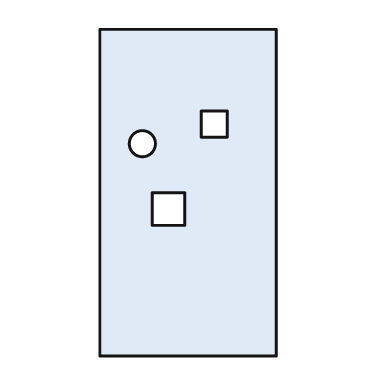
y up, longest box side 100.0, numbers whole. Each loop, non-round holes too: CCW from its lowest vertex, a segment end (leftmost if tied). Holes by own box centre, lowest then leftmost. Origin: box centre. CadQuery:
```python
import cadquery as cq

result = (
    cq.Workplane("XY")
    .moveTo(-27.0, -50.0)
    .lineTo(27.0, -50.0)
    .lineTo(27.0, 50.0)
    .lineTo(-27.0, 50.0)
    .close()
    .moveTo(-11.0, -10.0)
    .lineTo(-1.0, -10.0)
    .lineTo(-1.0, 0.0)
    .lineTo(-11.0, 0.0)
    .close()
    .moveTo(-14.0, 15.0)
    .circle(4.0)
    .moveTo(4.0, 17.0)
    .lineTo(12.0, 17.0)
    .lineTo(12.0, 25.0)
    .lineTo(4.0, 25.0)
    .close()
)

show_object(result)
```